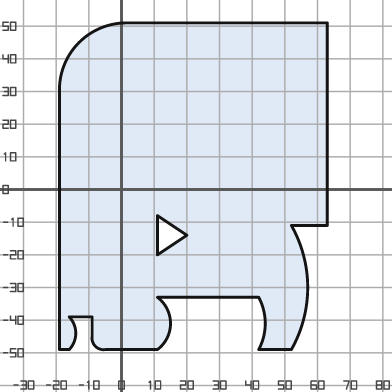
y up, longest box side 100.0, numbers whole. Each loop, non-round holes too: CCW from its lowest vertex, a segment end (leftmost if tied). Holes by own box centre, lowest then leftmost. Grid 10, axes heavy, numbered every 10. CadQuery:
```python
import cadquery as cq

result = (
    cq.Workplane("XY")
    .moveTo(-19.0, -49.0)
    .lineTo(-16.0, -49.0)
    .threePointArc((-14.0, -44.0), (-16.0, -39.0))
    .lineTo(-9.0, -39.0)
    .lineTo(-9.0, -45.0)
    .threePointArc((-8.0, -48.0), (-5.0, -49.0))
    .lineTo(11.0, -49.0)
    .threePointArc((15.0, -41.0), (11.0, -33.0))
    .lineTo(42.0, -33.0)
    .threePointArc((44.0, -41.0), (42.0, -49.0))
    .lineTo(52.0, -49.0)
    .threePointArc((57.0, -30.0), (52.0, -11.0))
    .lineTo(63.0, -11.0)
    .lineTo(63.0, 51.0)
    .lineTo(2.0, 51.0)
    .threePointArc((-13.0, 45.0), (-19.0, 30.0))
    .close()
    .moveTo(11.0, -20.0)
    .lineTo(20.0, -14.0)
    .lineTo(11.0, -8.0)
    .close()
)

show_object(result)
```